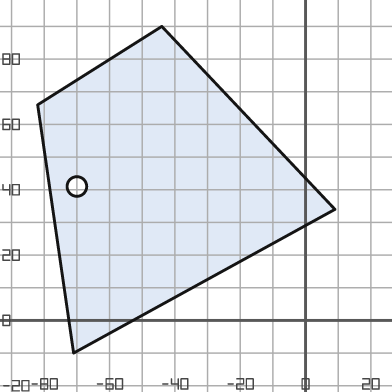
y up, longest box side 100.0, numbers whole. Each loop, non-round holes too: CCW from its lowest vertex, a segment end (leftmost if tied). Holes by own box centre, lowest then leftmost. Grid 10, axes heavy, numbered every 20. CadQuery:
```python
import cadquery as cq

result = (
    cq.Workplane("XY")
    .moveTo(-71.0, -10.0)
    .lineTo(9.0, 34.0)
    .lineTo(-44.0, 90.0)
    .lineTo(-82.0, 66.0)
    .close()
    .moveTo(-70.0, 41.0)
    .circle(3.0)
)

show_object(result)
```